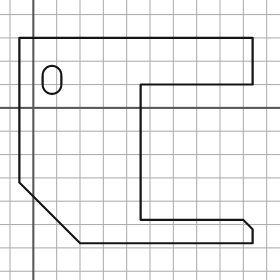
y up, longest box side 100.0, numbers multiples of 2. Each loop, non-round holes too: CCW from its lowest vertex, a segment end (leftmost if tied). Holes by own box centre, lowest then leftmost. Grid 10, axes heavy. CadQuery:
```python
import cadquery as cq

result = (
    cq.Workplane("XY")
    .moveTo(20.0, -58.0)
    .lineTo(94.0, -58.0)
    .lineTo(94.0, -52.0)
    .lineTo(90.0, -48.0)
    .lineTo(46.0, -48.0)
    .lineTo(46.0, 10.0)
    .lineTo(94.0, 10.0)
    .lineTo(94.0, 30.0)
    .lineTo(-6.0, 30.0)
    .lineTo(-6.0, -32.0)
    .close()
    .moveTo(4.0, 10.0)
    .threePointArc((8.0, 6.0), (12.0, 10.0))
    .lineTo(12.0, 14.0)
    .threePointArc((8.0, 18.0), (4.0, 14.0))
    .close()
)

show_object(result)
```